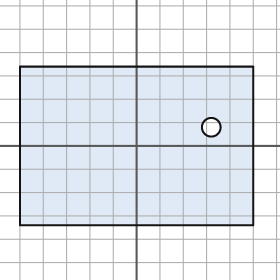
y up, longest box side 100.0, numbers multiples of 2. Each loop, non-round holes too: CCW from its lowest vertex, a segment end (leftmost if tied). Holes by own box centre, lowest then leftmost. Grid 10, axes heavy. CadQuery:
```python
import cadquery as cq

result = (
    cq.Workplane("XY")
    .moveTo(-50.0, -34.0)
    .lineTo(50.0, -34.0)
    .lineTo(50.0, 34.0)
    .lineTo(-50.0, 34.0)
    .close()
    .moveTo(32.0, 8.0)
    .circle(4.0)
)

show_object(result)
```